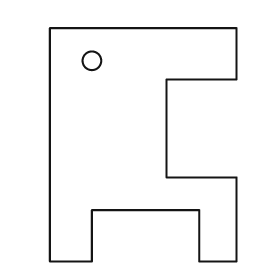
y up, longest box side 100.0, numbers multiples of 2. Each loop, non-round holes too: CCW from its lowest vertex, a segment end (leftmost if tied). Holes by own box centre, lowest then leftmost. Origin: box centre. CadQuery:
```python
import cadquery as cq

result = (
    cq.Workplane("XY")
    .moveTo(-40.0, -50.0)
    .lineTo(-22.0, -50.0)
    .lineTo(-22.0, -28.0)
    .lineTo(24.0, -28.0)
    .lineTo(24.0, -50.0)
    .lineTo(40.0, -50.0)
    .lineTo(40.0, -14.0)
    .lineTo(10.0, -14.0)
    .lineTo(10.0, 28.0)
    .lineTo(40.0, 28.0)
    .lineTo(40.0, 50.0)
    .lineTo(-40.0, 50.0)
    .close()
    .moveTo(-22.0, 36.0)
    .circle(4.0)
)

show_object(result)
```